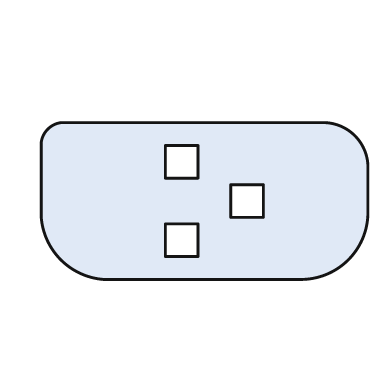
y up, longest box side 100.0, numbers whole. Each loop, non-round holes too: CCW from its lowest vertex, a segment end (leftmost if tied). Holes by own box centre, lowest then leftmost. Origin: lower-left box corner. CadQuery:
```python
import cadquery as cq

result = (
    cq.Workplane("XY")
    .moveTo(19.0, 0.0)
    .lineTo(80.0, 0.0)
    .threePointArc((94.0, 6.0), (100.0, 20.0))
    .lineTo(100.0, 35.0)
    .threePointArc((96.0, 44.0), (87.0, 48.0))
    .lineTo(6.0, 48.0)
    .threePointArc((2.0, 46.0), (0.0, 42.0))
    .lineTo(0.0, 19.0)
    .threePointArc((6.0, 6.0), (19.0, 0.0))
    .close()
    .moveTo(38.0, 7.0)
    .lineTo(48.0, 7.0)
    .lineTo(48.0, 17.0)
    .lineTo(38.0, 17.0)
    .close()
    .moveTo(58.0, 19.0)
    .lineTo(68.0, 19.0)
    .lineTo(68.0, 29.0)
    .lineTo(58.0, 29.0)
    .close()
    .moveTo(38.0, 31.0)
    .lineTo(48.0, 31.0)
    .lineTo(48.0, 41.0)
    .lineTo(38.0, 41.0)
    .close()
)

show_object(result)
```